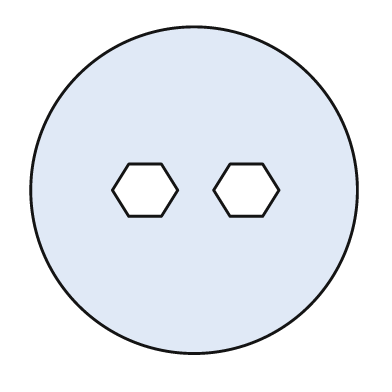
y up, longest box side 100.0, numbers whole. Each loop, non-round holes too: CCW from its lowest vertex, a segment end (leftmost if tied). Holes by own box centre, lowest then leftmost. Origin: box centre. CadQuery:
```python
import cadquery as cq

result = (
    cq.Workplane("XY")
    .moveTo(0.0, 0.0)
    .circle(50.0)
    .moveTo(-20.0, -8.0)
    .lineTo(-10.0, -8.0)
    .lineTo(-5.0, 0.0)
    .lineTo(-10.0, 8.0)
    .lineTo(-20.0, 8.0)
    .lineTo(-25.0, 0.0)
    .close()
    .moveTo(11.0, -8.0)
    .lineTo(21.0, -8.0)
    .lineTo(26.0, 0.0)
    .lineTo(21.0, 8.0)
    .lineTo(11.0, 8.0)
    .lineTo(6.0, 0.0)
    .close()
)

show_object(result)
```